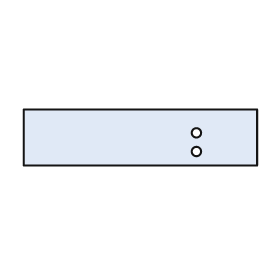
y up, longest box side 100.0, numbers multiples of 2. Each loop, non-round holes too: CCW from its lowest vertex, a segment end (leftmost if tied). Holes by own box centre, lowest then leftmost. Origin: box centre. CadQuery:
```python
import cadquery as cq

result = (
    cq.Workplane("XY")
    .moveTo(-50.0, -12.0)
    .lineTo(50.0, -12.0)
    .lineTo(50.0, 12.0)
    .lineTo(-50.0, 12.0)
    .close()
    .moveTo(24.0, -6.0)
    .circle(2.0)
    .moveTo(24.0, 2.0)
    .circle(2.0)
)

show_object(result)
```